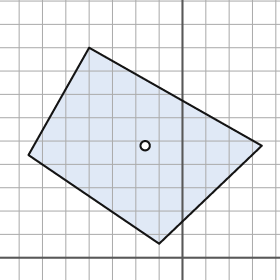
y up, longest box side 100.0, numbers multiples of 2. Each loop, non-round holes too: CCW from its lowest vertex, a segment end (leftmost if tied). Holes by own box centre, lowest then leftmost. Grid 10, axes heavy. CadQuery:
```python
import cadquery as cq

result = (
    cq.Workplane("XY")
    .moveTo(-10.0, 6.0)
    .lineTo(34.0, 48.0)
    .lineTo(-40.0, 90.0)
    .lineTo(-66.0, 44.0)
    .close()
    .moveTo(-16.0, 48.0)
    .circle(2.0)
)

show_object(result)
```